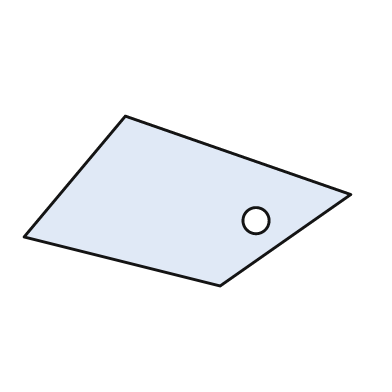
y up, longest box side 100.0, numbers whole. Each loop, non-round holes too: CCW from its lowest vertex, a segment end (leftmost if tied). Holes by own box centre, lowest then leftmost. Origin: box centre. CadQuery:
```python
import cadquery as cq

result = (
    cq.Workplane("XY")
    .moveTo(10.0, -26.0)
    .lineTo(50.0, 2.0)
    .lineTo(-19.0, 26.0)
    .lineTo(-50.0, -11.0)
    .close()
    .moveTo(21.0, -6.0)
    .circle(4.0)
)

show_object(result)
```